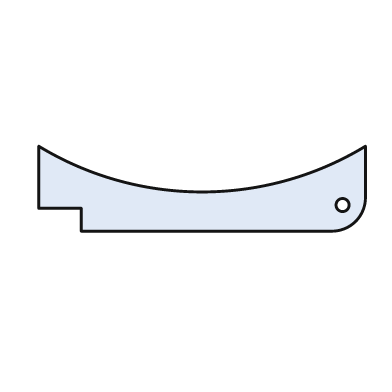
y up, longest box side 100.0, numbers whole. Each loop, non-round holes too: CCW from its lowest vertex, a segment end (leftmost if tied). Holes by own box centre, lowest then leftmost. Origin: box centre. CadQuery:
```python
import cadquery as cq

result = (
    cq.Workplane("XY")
    .moveTo(-37.0, -13.0)
    .lineTo(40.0, -13.0)
    .threePointArc((47.0, -10.0), (50.0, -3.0))
    .lineTo(50.0, 13.0)
    .threePointArc((0.0, -1.0), (-50.0, 13.0))
    .lineTo(-50.0, -6.0)
    .lineTo(-37.0, -6.0)
    .close()
    .moveTo(43.0, -5.0)
    .circle(2.0)
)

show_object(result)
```